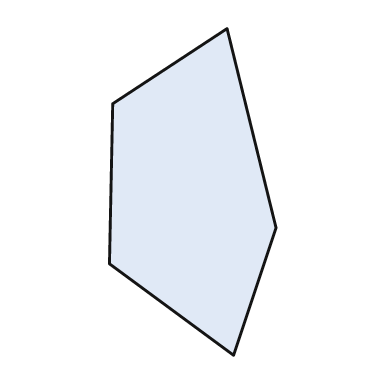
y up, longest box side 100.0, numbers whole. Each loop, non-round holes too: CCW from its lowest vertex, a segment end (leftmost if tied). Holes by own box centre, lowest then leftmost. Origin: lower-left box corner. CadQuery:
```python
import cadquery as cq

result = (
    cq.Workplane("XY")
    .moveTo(38.0, 0.0)
    .lineTo(51.0, 39.0)
    .lineTo(36.0, 100.0)
    .lineTo(1.0, 77.0)
    .lineTo(0.0, 28.0)
    .close()
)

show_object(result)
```